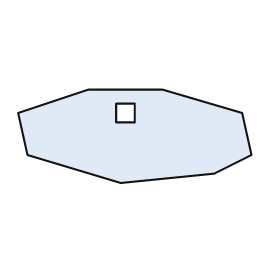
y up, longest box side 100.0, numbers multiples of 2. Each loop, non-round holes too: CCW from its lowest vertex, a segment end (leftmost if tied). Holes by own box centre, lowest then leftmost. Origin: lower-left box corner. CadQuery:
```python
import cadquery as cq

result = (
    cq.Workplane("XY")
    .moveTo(44.0, 0.0)
    .lineTo(84.0, 4.0)
    .lineTo(100.0, 12.0)
    .lineTo(96.0, 30.0)
    .lineTo(62.0, 40.0)
    .lineTo(30.0, 40.0)
    .lineTo(0.0, 30.0)
    .lineTo(4.0, 12.0)
    .close()
    .moveTo(42.0, 26.0)
    .lineTo(50.0, 26.0)
    .lineTo(50.0, 34.0)
    .lineTo(42.0, 34.0)
    .close()
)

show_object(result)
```